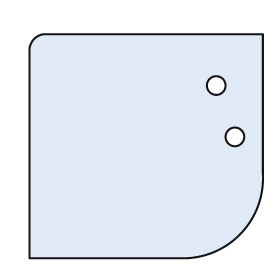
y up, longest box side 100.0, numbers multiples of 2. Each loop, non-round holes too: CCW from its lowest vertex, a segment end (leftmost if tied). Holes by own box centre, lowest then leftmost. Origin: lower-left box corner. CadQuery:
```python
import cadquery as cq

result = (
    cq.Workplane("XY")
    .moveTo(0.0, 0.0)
    .lineTo(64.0, 0.0)
    .threePointArc((90.0, 10.0), (100.0, 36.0))
    .lineTo(100.0, 96.0)
    .lineTo(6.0, 96.0)
    .threePointArc((2.0, 94.0), (0.0, 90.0))
    .close()
    .moveTo(88.0, 52.0)
    .circle(4.0)
    .moveTo(80.0, 74.0)
    .circle(4.0)
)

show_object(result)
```